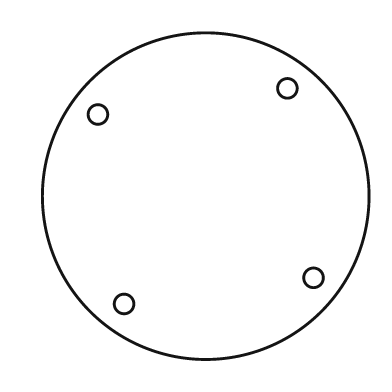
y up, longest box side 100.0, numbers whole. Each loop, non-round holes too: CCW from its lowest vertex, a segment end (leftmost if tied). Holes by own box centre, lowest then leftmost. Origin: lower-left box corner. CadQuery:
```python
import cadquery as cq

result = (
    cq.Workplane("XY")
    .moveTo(50.0, 50.0)
    .circle(50.0)
    .moveTo(25.0, 17.0)
    .circle(3.0)
    .moveTo(83.0, 25.0)
    .circle(3.0)
    .moveTo(17.0, 75.0)
    .circle(3.0)
    .moveTo(75.0, 83.0)
    .circle(3.0)
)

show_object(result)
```